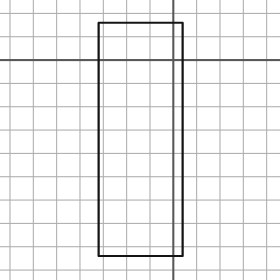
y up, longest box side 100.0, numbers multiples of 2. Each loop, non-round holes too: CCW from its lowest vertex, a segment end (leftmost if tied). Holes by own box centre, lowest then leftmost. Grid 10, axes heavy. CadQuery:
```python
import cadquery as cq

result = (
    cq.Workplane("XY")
    .moveTo(-32.0, -84.0)
    .lineTo(4.0, -84.0)
    .lineTo(4.0, 16.0)
    .lineTo(-32.0, 16.0)
    .close()
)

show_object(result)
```